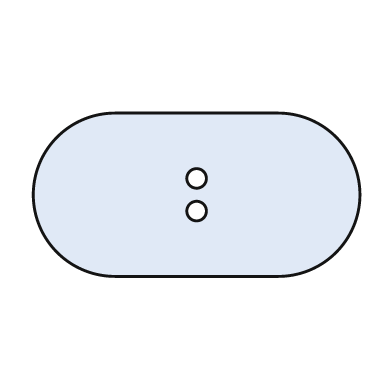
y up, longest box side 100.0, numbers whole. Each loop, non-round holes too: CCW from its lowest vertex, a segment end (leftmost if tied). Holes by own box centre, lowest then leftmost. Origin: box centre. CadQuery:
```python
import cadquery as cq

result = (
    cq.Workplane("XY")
    .moveTo(-25.0, -25.0)
    .lineTo(25.0, -25.0)
    .threePointArc((50.0, 0.0), (25.0, 25.0))
    .lineTo(-25.0, 25.0)
    .threePointArc((-50.0, 0.0), (-25.0, -25.0))
    .close()
    .moveTo(0.0, -5.0)
    .circle(3.0)
    .moveTo(0.0, 5.0)
    .circle(3.0)
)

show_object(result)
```